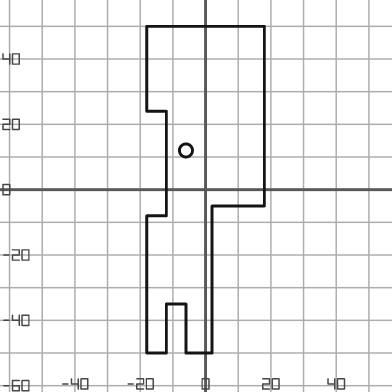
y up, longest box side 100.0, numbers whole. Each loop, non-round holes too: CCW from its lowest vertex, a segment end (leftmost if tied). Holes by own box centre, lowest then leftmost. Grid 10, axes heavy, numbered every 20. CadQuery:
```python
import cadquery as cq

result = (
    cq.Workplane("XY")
    .moveTo(-18.0, -50.0)
    .lineTo(-12.0, -50.0)
    .lineTo(-12.0, -35.0)
    .lineTo(-6.0, -35.0)
    .lineTo(-6.0, -50.0)
    .lineTo(2.0, -50.0)
    .lineTo(2.0, -5.0)
    .lineTo(18.0, -5.0)
    .lineTo(18.0, 50.0)
    .lineTo(-18.0, 50.0)
    .lineTo(-18.0, 24.0)
    .lineTo(-12.0, 24.0)
    .lineTo(-12.0, -8.0)
    .lineTo(-18.0, -8.0)
    .close()
    .moveTo(-6.0, 12.0)
    .circle(2.0)
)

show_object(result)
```